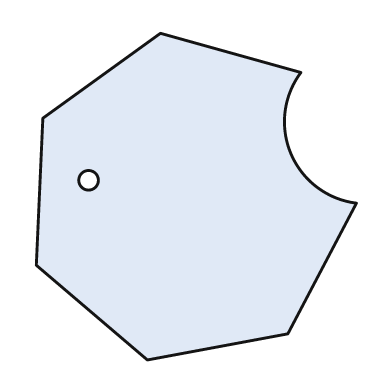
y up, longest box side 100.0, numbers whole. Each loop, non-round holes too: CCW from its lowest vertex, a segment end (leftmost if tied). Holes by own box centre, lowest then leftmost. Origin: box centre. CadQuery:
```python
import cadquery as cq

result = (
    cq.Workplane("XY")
    .moveTo(-15.0, -50.0)
    .lineTo(28.0, -42.0)
    .lineTo(49.0, -2.0)
    .threePointArc((29.0, 13.0), (32.0, 38.0))
    .lineTo(-11.0, 50.0)
    .lineTo(-47.0, 24.0)
    .lineTo(-49.0, -21.0)
    .close()
    .moveTo(-33.0, 5.0)
    .circle(3.0)
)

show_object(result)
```